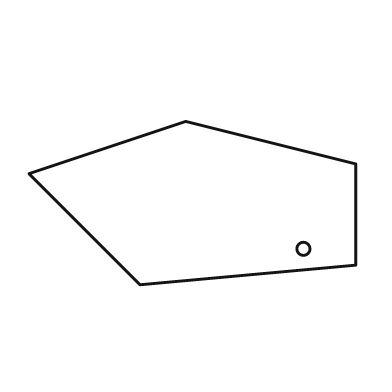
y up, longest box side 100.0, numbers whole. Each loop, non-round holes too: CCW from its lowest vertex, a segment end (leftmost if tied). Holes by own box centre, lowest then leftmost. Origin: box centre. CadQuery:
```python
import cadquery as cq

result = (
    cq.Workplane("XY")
    .moveTo(-16.0, -25.0)
    .lineTo(50.0, -19.0)
    .lineTo(50.0, 12.0)
    .lineTo(-2.0, 25.0)
    .lineTo(-50.0, 9.0)
    .close()
    .moveTo(34.0, -14.0)
    .circle(2.0)
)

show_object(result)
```